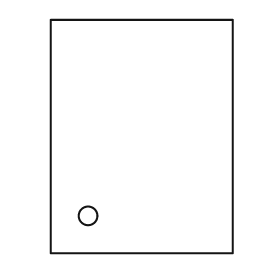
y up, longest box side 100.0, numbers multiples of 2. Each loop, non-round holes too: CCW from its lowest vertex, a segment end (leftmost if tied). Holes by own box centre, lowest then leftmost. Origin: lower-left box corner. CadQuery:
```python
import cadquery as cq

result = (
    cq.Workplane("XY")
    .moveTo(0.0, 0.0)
    .lineTo(78.0, 0.0)
    .lineTo(78.0, 100.0)
    .lineTo(0.0, 100.0)
    .close()
    .moveTo(16.0, 16.0)
    .circle(4.0)
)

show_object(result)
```